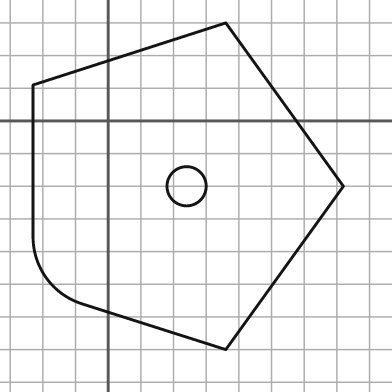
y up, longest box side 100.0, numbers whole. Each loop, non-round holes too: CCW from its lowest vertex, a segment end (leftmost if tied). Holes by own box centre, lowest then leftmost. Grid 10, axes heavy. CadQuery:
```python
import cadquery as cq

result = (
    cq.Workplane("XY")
    .moveTo(36.0, -70.0)
    .lineTo(72.0, -20.0)
    .lineTo(36.0, 30.0)
    .lineTo(-23.0, 11.0)
    .lineTo(-23.0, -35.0)
    .threePointArc((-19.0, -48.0), (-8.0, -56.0))
    .close()
    .moveTo(24.0, -20.0)
    .circle(6.0)
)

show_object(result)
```